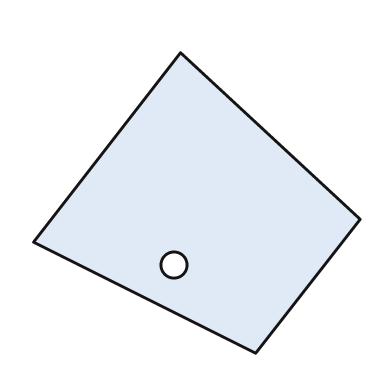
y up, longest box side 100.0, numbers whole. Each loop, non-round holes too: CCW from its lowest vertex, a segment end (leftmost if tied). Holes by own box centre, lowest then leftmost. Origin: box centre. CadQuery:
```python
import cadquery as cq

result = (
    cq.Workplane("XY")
    .moveTo(18.0, -46.0)
    .lineTo(50.0, -5.0)
    .lineTo(-5.0, 46.0)
    .lineTo(-50.0, -12.0)
    .close()
    .moveTo(-7.0, -19.0)
    .circle(4.0)
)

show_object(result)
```